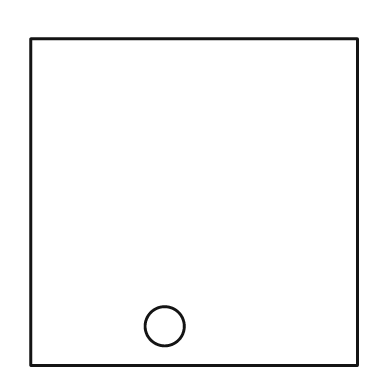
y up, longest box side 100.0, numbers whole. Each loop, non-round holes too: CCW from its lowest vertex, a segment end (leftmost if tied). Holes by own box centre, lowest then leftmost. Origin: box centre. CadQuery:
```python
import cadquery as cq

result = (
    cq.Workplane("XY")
    .moveTo(-50.0, -50.0)
    .lineTo(50.0, -50.0)
    .lineTo(50.0, 50.0)
    .lineTo(-50.0, 50.0)
    .close()
    .moveTo(-9.0, -38.0)
    .circle(6.0)
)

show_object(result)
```